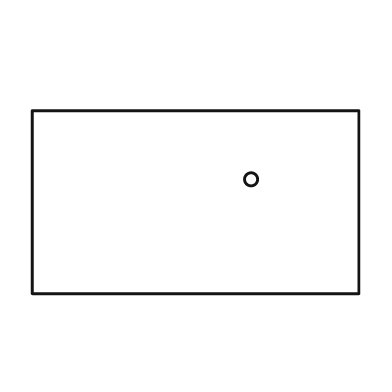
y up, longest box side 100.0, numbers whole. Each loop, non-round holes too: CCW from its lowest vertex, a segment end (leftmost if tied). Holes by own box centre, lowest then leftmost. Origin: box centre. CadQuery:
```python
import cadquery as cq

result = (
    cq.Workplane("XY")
    .moveTo(-50.0, -28.0)
    .lineTo(50.0, -28.0)
    .lineTo(50.0, 28.0)
    .lineTo(-50.0, 28.0)
    .close()
    .moveTo(17.0, 7.0)
    .circle(2.0)
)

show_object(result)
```